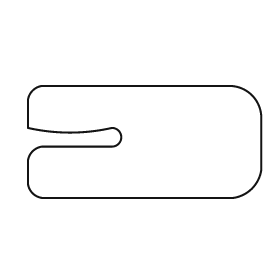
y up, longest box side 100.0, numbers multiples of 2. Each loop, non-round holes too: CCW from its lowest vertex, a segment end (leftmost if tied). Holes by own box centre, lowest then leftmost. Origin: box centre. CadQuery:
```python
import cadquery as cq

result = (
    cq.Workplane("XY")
    .moveTo(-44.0, -24.0)
    .lineTo(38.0, -24.0)
    .threePointArc((46.0, -20.0), (50.0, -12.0))
    .lineTo(50.0, 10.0)
    .threePointArc((46.0, 20.0), (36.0, 24.0))
    .lineTo(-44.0, 24.0)
    .threePointArc((-48.0, 22.0), (-50.0, 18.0))
    .lineTo(-50.0, 6.0)
    .threePointArc((-32.0, 4.0), (-14.0, 6.0))
    .threePointArc((-10.0, 2.0), (-14.0, -2.0))
    .lineTo(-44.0, -2.0)
    .threePointArc((-48.0, -4.0), (-50.0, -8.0))
    .lineTo(-50.0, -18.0)
    .threePointArc((-48.0, -22.0), (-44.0, -24.0))
    .close()
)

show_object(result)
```